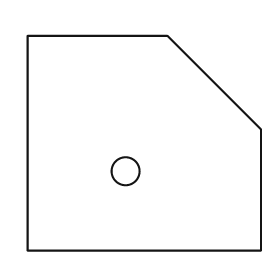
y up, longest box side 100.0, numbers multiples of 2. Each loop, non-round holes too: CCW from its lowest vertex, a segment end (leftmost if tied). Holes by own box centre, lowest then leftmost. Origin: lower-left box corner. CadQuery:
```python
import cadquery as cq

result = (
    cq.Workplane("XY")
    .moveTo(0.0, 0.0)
    .lineTo(100.0, 0.0)
    .lineTo(100.0, 52.0)
    .lineTo(60.0, 92.0)
    .lineTo(0.0, 92.0)
    .close()
    .moveTo(42.0, 34.0)
    .circle(6.0)
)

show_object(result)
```